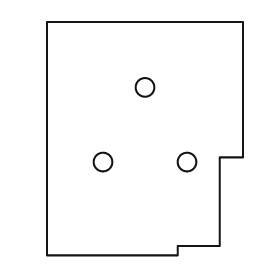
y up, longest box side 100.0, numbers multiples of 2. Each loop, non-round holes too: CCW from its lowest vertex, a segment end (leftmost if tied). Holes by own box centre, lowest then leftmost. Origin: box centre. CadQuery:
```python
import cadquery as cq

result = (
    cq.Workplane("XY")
    .moveTo(-42.0, -50.0)
    .lineTo(14.0, -50.0)
    .lineTo(14.0, -46.0)
    .lineTo(32.0, -46.0)
    .lineTo(32.0, -8.0)
    .lineTo(42.0, -8.0)
    .lineTo(42.0, 50.0)
    .lineTo(-42.0, 50.0)
    .close()
    .moveTo(-18.0, -10.0)
    .circle(4.0)
    .moveTo(18.0, -10.0)
    .circle(4.0)
    .moveTo(0.0, 22.0)
    .circle(4.0)
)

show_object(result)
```